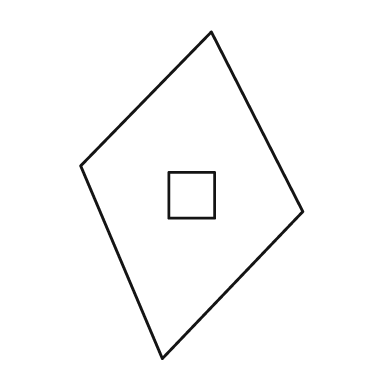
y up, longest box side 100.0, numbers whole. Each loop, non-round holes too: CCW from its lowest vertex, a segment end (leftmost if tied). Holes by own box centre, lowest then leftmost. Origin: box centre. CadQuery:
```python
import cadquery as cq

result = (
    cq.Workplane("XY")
    .moveTo(-9.0, -50.0)
    .lineTo(34.0, -5.0)
    .lineTo(6.0, 50.0)
    .lineTo(-34.0, 9.0)
    .close()
    .moveTo(-7.0, -7.0)
    .lineTo(7.0, -7.0)
    .lineTo(7.0, 7.0)
    .lineTo(-7.0, 7.0)
    .close()
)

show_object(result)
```